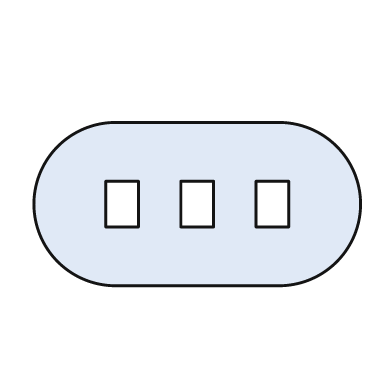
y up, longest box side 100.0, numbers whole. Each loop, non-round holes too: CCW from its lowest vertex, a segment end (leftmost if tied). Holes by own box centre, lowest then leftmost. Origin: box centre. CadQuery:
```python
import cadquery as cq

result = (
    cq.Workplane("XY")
    .moveTo(-25.0, -25.0)
    .lineTo(25.0, -25.0)
    .threePointArc((50.0, 0.0), (25.0, 25.0))
    .lineTo(-25.0, 25.0)
    .threePointArc((-50.0, 0.0), (-25.0, -25.0))
    .close()
    .moveTo(-28.0, -7.0)
    .lineTo(-18.0, -7.0)
    .lineTo(-18.0, 7.0)
    .lineTo(-28.0, 7.0)
    .close()
    .moveTo(-5.0, -7.0)
    .lineTo(5.0, -7.0)
    .lineTo(5.0, 7.0)
    .lineTo(-5.0, 7.0)
    .close()
    .moveTo(18.0, -7.0)
    .lineTo(28.0, -7.0)
    .lineTo(28.0, 7.0)
    .lineTo(18.0, 7.0)
    .close()
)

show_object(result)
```